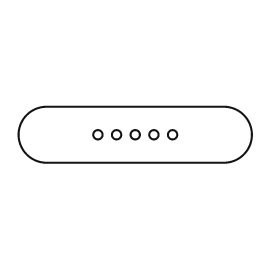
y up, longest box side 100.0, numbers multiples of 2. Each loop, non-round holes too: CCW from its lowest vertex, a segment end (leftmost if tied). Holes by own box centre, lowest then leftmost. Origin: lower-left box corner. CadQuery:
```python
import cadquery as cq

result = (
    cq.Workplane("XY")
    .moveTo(12.0, 0.0)
    .lineTo(88.0, 0.0)
    .threePointArc((100.0, 12.0), (88.0, 24.0))
    .lineTo(12.0, 24.0)
    .threePointArc((0.0, 12.0), (12.0, 0.0))
    .close()
    .moveTo(34.0, 12.0)
    .circle(2.0)
    .moveTo(42.0, 12.0)
    .circle(2.0)
    .moveTo(50.0, 12.0)
    .circle(2.0)
    .moveTo(58.0, 12.0)
    .circle(2.0)
    .moveTo(66.0, 12.0)
    .circle(2.0)
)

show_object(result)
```